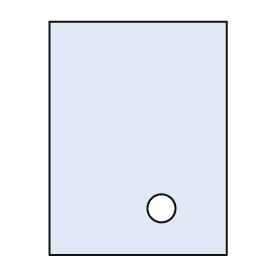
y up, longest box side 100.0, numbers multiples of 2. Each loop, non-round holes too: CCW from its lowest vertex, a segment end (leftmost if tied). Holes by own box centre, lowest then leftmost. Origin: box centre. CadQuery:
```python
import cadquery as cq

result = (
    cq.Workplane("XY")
    .moveTo(-38.0, -50.0)
    .lineTo(38.0, -50.0)
    .lineTo(38.0, 50.0)
    .lineTo(-38.0, 50.0)
    .close()
    .moveTo(10.0, -30.0)
    .circle(6.0)
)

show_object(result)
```